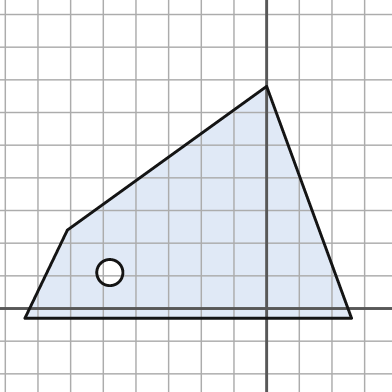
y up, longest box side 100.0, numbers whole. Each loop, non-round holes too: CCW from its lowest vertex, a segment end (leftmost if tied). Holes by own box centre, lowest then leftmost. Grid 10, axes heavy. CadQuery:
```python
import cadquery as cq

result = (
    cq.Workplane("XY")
    .moveTo(-74.0, -3.0)
    .lineTo(26.0, -3.0)
    .lineTo(0.0, 68.0)
    .lineTo(-61.0, 24.0)
    .close()
    .moveTo(-48.0, 11.0)
    .circle(4.0)
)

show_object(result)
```